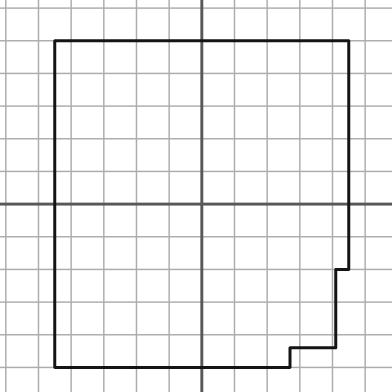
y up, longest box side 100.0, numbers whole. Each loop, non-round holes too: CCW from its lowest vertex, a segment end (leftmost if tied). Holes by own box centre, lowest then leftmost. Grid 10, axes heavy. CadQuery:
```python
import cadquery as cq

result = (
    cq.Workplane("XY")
    .moveTo(-45.0, -50.0)
    .lineTo(27.0, -50.0)
    .lineTo(27.0, -44.0)
    .lineTo(41.0, -44.0)
    .lineTo(41.0, -20.0)
    .lineTo(45.0, -20.0)
    .lineTo(45.0, 50.0)
    .lineTo(-45.0, 50.0)
    .close()
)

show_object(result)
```